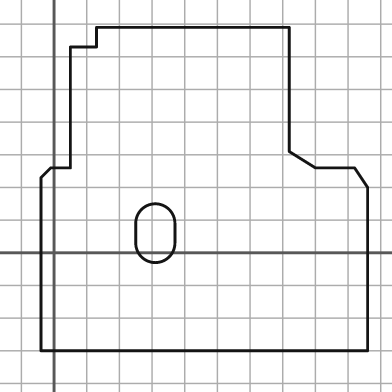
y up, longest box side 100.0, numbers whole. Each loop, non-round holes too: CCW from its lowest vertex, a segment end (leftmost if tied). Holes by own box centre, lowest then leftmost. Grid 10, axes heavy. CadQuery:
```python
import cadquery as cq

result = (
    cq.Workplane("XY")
    .moveTo(-4.0, -30.0)
    .lineTo(96.0, -30.0)
    .lineTo(96.0, 20.0)
    .lineTo(92.0, 26.0)
    .lineTo(80.0, 26.0)
    .lineTo(72.0, 31.0)
    .lineTo(72.0, 69.0)
    .lineTo(13.0, 69.0)
    .lineTo(13.0, 63.0)
    .lineTo(5.0, 63.0)
    .lineTo(5.0, 26.0)
    .lineTo(-1.0, 26.0)
    .lineTo(-4.0, 23.0)
    .close()
    .moveTo(25.0, 3.0)
    .threePointArc((31.0, -3.0), (37.0, 3.0))
    .lineTo(37.0, 9.0)
    .threePointArc((31.0, 15.0), (25.0, 9.0))
    .close()
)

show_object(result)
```